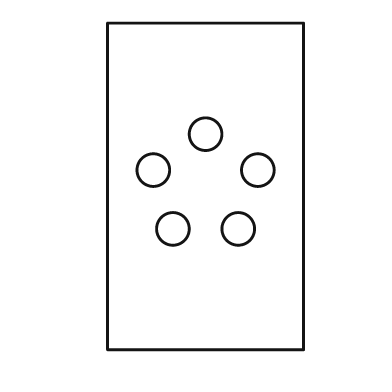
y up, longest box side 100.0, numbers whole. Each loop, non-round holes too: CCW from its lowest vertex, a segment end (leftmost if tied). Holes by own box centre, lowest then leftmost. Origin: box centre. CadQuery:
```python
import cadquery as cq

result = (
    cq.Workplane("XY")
    .moveTo(-30.0, -50.0)
    .lineTo(30.0, -50.0)
    .lineTo(30.0, 50.0)
    .lineTo(-30.0, 50.0)
    .close()
    .moveTo(-10.0, -13.0)
    .circle(5.0)
    .moveTo(10.0, -13.0)
    .circle(5.0)
    .moveTo(-16.0, 5.0)
    .circle(5.0)
    .moveTo(16.0, 5.0)
    .circle(5.0)
    .moveTo(0.0, 16.0)
    .circle(5.0)
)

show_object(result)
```